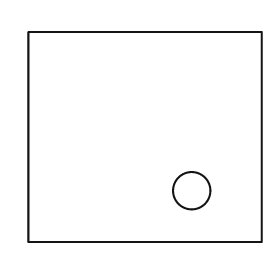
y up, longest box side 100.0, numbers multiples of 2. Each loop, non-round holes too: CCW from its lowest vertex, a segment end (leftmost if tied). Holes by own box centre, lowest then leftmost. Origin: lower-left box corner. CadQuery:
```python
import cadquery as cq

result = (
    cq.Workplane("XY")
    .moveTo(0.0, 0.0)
    .lineTo(100.0, 0.0)
    .lineTo(100.0, 90.0)
    .lineTo(0.0, 90.0)
    .close()
    .moveTo(70.0, 22.0)
    .circle(8.0)
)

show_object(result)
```